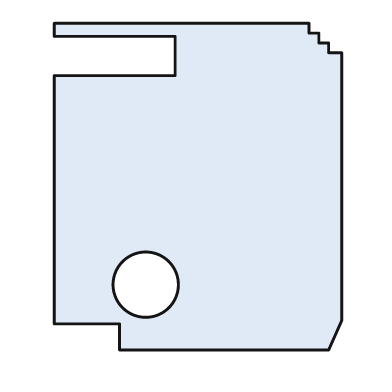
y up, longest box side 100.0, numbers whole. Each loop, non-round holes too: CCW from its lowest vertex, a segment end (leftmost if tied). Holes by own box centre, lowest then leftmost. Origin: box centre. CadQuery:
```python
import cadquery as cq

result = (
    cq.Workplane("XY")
    .moveTo(-24.0, -50.0)
    .lineTo(40.0, -50.0)
    .lineTo(44.0, -41.0)
    .lineTo(44.0, 41.0)
    .lineTo(40.0, 41.0)
    .lineTo(40.0, 44.0)
    .lineTo(37.0, 44.0)
    .lineTo(37.0, 47.0)
    .lineTo(34.0, 47.0)
    .lineTo(34.0, 50.0)
    .lineTo(-44.0, 50.0)
    .lineTo(-44.0, 46.0)
    .lineTo(-7.0, 46.0)
    .lineTo(-7.0, 34.0)
    .lineTo(-44.0, 34.0)
    .lineTo(-44.0, -42.0)
    .lineTo(-24.0, -42.0)
    .close()
    .moveTo(-16.0, -30.0)
    .circle(10.0)
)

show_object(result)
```